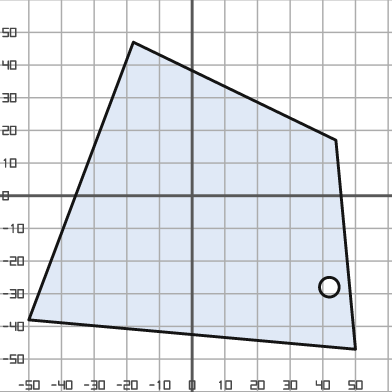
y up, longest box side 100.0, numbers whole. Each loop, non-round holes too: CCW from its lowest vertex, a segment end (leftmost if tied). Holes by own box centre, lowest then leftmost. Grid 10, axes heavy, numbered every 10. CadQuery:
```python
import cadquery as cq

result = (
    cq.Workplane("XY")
    .moveTo(50.0, -47.0)
    .lineTo(44.0, 17.0)
    .lineTo(-18.0, 47.0)
    .lineTo(-50.0, -38.0)
    .close()
    .moveTo(42.0, -28.0)
    .circle(3.0)
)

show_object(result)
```